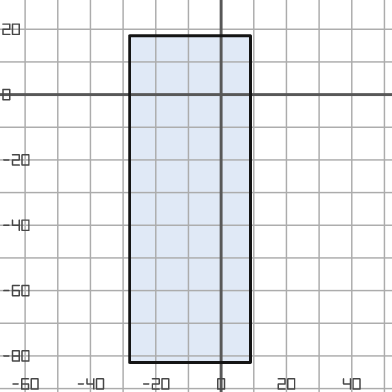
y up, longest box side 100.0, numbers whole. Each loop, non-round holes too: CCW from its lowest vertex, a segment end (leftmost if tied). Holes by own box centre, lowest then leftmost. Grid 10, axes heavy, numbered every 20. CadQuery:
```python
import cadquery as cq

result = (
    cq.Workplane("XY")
    .moveTo(-28.0, -82.0)
    .lineTo(9.0, -82.0)
    .lineTo(9.0, 18.0)
    .lineTo(-28.0, 18.0)
    .close()
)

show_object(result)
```